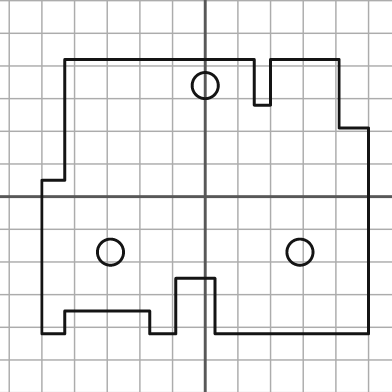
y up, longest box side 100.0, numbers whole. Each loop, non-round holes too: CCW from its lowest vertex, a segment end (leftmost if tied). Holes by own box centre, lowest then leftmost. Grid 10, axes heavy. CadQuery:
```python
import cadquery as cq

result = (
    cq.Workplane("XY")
    .moveTo(-50.0, -42.0)
    .lineTo(-43.0, -42.0)
    .lineTo(-43.0, -35.0)
    .lineTo(-17.0, -35.0)
    .lineTo(-17.0, -42.0)
    .lineTo(-9.0, -42.0)
    .lineTo(-9.0, -25.0)
    .lineTo(3.0, -25.0)
    .lineTo(3.0, -42.0)
    .lineTo(50.0, -42.0)
    .lineTo(50.0, 21.0)
    .lineTo(41.0, 21.0)
    .lineTo(41.0, 42.0)
    .lineTo(20.0, 42.0)
    .lineTo(20.0, 28.0)
    .lineTo(15.0, 28.0)
    .lineTo(15.0, 42.0)
    .lineTo(-43.0, 42.0)
    .lineTo(-43.0, 5.0)
    .lineTo(-50.0, 5.0)
    .close()
    .moveTo(-29.0, -17.0)
    .circle(4.0)
    .moveTo(29.0, -17.0)
    .circle(4.0)
    .moveTo(0.0, 34.0)
    .circle(4.0)
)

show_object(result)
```